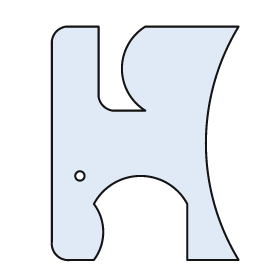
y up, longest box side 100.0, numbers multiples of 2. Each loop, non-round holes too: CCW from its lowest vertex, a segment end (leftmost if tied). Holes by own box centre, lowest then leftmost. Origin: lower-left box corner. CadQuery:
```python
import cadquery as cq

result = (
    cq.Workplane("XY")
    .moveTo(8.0, 0.0)
    .lineTo(18.0, 0.0)
    .threePointArc((22.0, 12.0), (18.0, 24.0))
    .threePointArc((38.0, 36.0), (58.0, 24.0))
    .lineTo(58.0, 0.0)
    .lineTo(80.0, 0.0)
    .threePointArc((66.0, 50.0), (80.0, 100.0))
    .lineTo(40.0, 100.0)
    .threePointArc((30.0, 82.0), (40.0, 64.0))
    .lineTo(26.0, 64.0)
    .threePointArc((22.0, 66.0), (20.0, 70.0))
    .lineTo(20.0, 100.0)
    .lineTo(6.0, 100.0)
    .threePointArc((2.0, 98.0), (0.0, 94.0))
    .lineTo(0.0, 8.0)
    .threePointArc((2.0, 2.0), (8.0, 0.0))
    .close()
    .moveTo(12.0, 36.0)
    .circle(2.0)
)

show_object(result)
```